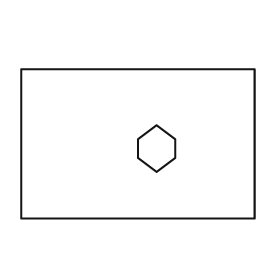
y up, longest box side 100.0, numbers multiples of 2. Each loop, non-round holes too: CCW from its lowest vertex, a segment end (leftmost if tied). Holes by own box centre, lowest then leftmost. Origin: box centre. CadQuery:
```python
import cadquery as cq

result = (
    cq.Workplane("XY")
    .moveTo(-50.0, -32.0)
    .lineTo(50.0, -32.0)
    .lineTo(50.0, 32.0)
    .lineTo(-50.0, 32.0)
    .close()
    .moveTo(8.0, -12.0)
    .lineTo(16.0, -6.0)
    .lineTo(16.0, 2.0)
    .lineTo(8.0, 8.0)
    .lineTo(0.0, 2.0)
    .lineTo(0.0, -6.0)
    .close()
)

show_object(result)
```